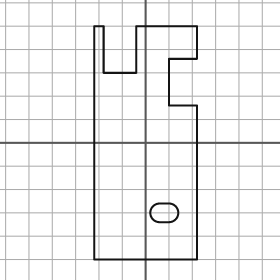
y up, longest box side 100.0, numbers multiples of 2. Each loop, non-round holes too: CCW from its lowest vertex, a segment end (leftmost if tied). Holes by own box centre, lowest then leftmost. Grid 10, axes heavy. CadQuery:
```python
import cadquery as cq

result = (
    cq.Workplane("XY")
    .moveTo(-22.0, -50.0)
    .lineTo(22.0, -50.0)
    .lineTo(22.0, 16.0)
    .lineTo(10.0, 16.0)
    .lineTo(10.0, 36.0)
    .lineTo(22.0, 36.0)
    .lineTo(22.0, 50.0)
    .lineTo(-4.0, 50.0)
    .lineTo(-4.0, 30.0)
    .lineTo(-18.0, 30.0)
    .lineTo(-18.0, 50.0)
    .lineTo(-22.0, 50.0)
    .close()
    .moveTo(6.0, -34.0)
    .lineTo(10.0, -34.0)
    .threePointArc((14.0, -30.0), (10.0, -26.0))
    .lineTo(6.0, -26.0)
    .threePointArc((2.0, -30.0), (6.0, -34.0))
    .close()
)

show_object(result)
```